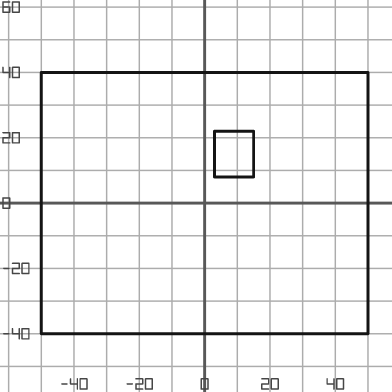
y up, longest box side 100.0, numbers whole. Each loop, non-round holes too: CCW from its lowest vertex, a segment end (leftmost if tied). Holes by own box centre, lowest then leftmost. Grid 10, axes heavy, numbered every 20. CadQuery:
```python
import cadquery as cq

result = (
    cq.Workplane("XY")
    .moveTo(-50.0, -40.0)
    .lineTo(50.0, -40.0)
    .lineTo(50.0, 40.0)
    .lineTo(-50.0, 40.0)
    .close()
    .moveTo(3.0, 8.0)
    .lineTo(15.0, 8.0)
    .lineTo(15.0, 22.0)
    .lineTo(3.0, 22.0)
    .close()
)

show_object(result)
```